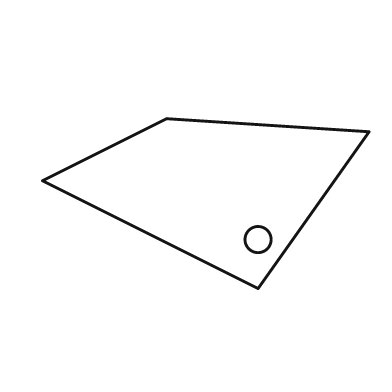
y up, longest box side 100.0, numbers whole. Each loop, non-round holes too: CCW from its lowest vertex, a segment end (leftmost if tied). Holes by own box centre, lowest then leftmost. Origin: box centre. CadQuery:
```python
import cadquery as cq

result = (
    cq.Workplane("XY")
    .moveTo(16.0, -26.0)
    .lineTo(50.0, 22.0)
    .lineTo(-12.0, 26.0)
    .lineTo(-50.0, 7.0)
    .close()
    .moveTo(16.0, -11.0)
    .circle(4.0)
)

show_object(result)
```